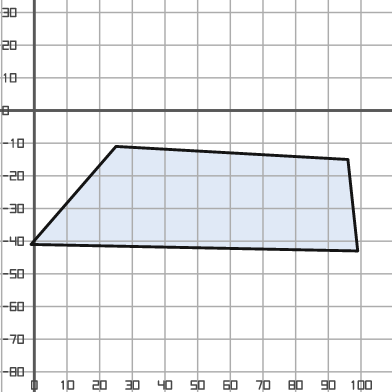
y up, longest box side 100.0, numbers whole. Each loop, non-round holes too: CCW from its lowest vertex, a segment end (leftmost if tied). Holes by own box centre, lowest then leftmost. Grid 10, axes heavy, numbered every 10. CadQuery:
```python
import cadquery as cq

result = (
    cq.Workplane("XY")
    .moveTo(99.0, -43.0)
    .lineTo(96.0, -15.0)
    .lineTo(25.0, -11.0)
    .lineTo(-1.0, -41.0)
    .close()
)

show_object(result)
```